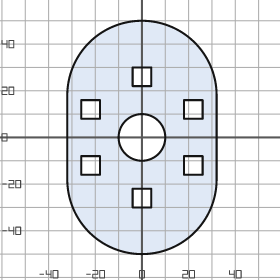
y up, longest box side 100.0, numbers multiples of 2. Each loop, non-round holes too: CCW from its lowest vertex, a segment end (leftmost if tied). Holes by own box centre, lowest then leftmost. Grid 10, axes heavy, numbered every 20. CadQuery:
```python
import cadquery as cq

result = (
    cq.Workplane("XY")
    .moveTo(-32.0, -18.0)
    .threePointArc((0.0, -50.0), (32.0, -18.0))
    .lineTo(32.0, 18.0)
    .threePointArc((0.0, 50.0), (-32.0, 18.0))
    .close()
    .moveTo(-4.0, -30.0)
    .lineTo(4.0, -30.0)
    .lineTo(4.0, -22.0)
    .lineTo(-4.0, -22.0)
    .close()
    .moveTo(-26.0, -16.0)
    .lineTo(-18.0, -16.0)
    .lineTo(-18.0, -8.0)
    .lineTo(-26.0, -8.0)
    .close()
    .moveTo(18.0, -16.0)
    .lineTo(26.0, -16.0)
    .lineTo(26.0, -8.0)
    .lineTo(18.0, -8.0)
    .close()
    .moveTo(0.0, 0.0)
    .circle(10.0)
    .moveTo(-26.0, 8.0)
    .lineTo(-18.0, 8.0)
    .lineTo(-18.0, 16.0)
    .lineTo(-26.0, 16.0)
    .close()
    .moveTo(18.0, 8.0)
    .lineTo(26.0, 8.0)
    .lineTo(26.0, 16.0)
    .lineTo(18.0, 16.0)
    .close()
    .moveTo(-4.0, 22.0)
    .lineTo(4.0, 22.0)
    .lineTo(4.0, 30.0)
    .lineTo(-4.0, 30.0)
    .close()
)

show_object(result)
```